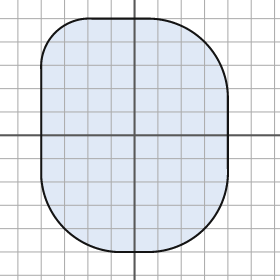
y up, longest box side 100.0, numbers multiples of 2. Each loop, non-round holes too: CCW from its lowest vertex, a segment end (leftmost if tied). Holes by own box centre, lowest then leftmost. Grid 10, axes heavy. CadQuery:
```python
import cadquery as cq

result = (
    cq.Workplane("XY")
    .moveTo(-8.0, -50.0)
    .lineTo(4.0, -50.0)
    .threePointArc((30.0, -40.0), (40.0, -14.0))
    .lineTo(40.0, 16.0)
    .threePointArc((30.0, 40.0), (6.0, 50.0))
    .lineTo(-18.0, 50.0)
    .threePointArc((-34.0, 44.0), (-40.0, 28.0))
    .lineTo(-40.0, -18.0)
    .threePointArc((-30.0, -40.0), (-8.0, -50.0))
    .close()
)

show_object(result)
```